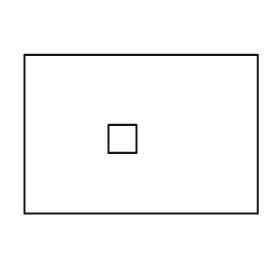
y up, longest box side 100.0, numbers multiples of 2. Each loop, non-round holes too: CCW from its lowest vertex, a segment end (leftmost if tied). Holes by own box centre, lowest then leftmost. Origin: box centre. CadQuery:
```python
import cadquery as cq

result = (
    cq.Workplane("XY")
    .moveTo(-50.0, -34.0)
    .lineTo(50.0, -34.0)
    .lineTo(50.0, 34.0)
    .lineTo(-50.0, 34.0)
    .close()
    .moveTo(-14.0, -8.0)
    .lineTo(-2.0, -8.0)
    .lineTo(-2.0, 4.0)
    .lineTo(-14.0, 4.0)
    .close()
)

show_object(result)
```